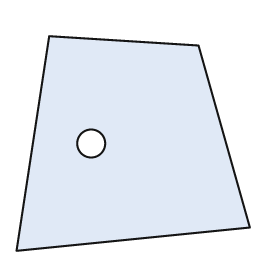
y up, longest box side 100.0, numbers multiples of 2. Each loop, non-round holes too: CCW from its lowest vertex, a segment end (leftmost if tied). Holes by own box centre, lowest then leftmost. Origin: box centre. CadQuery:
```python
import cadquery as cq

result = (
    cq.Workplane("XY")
    .moveTo(-50.0, -46.0)
    .lineTo(50.0, -36.0)
    .lineTo(28.0, 42.0)
    .lineTo(-36.0, 46.0)
    .close()
    .moveTo(-18.0, 0.0)
    .circle(6.0)
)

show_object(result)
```